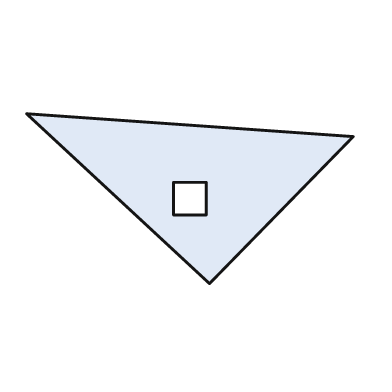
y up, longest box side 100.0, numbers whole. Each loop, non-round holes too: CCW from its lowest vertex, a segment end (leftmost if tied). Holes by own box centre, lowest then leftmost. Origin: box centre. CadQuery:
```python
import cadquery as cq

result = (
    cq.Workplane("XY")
    .moveTo(6.0, -26.0)
    .lineTo(50.0, 19.0)
    .lineTo(-50.0, 26.0)
    .close()
    .moveTo(-5.0, -5.0)
    .lineTo(5.0, -5.0)
    .lineTo(5.0, 5.0)
    .lineTo(-5.0, 5.0)
    .close()
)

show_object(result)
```